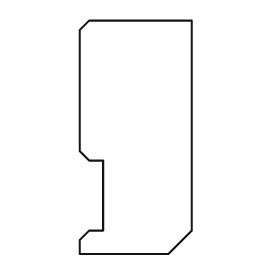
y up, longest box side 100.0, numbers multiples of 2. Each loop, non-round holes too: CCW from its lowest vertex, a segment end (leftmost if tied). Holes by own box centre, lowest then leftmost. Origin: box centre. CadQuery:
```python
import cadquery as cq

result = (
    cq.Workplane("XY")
    .moveTo(-24.0, -50.0)
    .lineTo(14.0, -50.0)
    .lineTo(24.0, -40.0)
    .lineTo(24.0, 50.0)
    .lineTo(-20.0, 50.0)
    .lineTo(-24.0, 46.0)
    .lineTo(-24.0, -6.0)
    .lineTo(-20.0, -10.0)
    .lineTo(-14.0, -10.0)
    .lineTo(-14.0, -40.0)
    .lineTo(-20.0, -40.0)
    .lineTo(-24.0, -44.0)
    .close()
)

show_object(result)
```